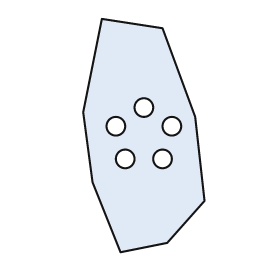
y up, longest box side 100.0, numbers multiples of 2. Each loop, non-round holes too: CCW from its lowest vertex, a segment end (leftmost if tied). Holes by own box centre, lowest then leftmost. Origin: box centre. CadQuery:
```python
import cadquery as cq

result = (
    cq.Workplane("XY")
    .moveTo(-10.0, -50.0)
    .lineTo(10.0, -46.0)
    .lineTo(26.0, -28.0)
    .lineTo(22.0, 8.0)
    .lineTo(8.0, 46.0)
    .lineTo(-18.0, 50.0)
    .lineTo(-26.0, 10.0)
    .lineTo(-22.0, -20.0)
    .close()
    .moveTo(-8.0, -10.0)
    .circle(4.0)
    .moveTo(8.0, -10.0)
    .circle(4.0)
    .moveTo(-12.0, 4.0)
    .circle(4.0)
    .moveTo(12.0, 4.0)
    .circle(4.0)
    .moveTo(0.0, 12.0)
    .circle(4.0)
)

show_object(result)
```